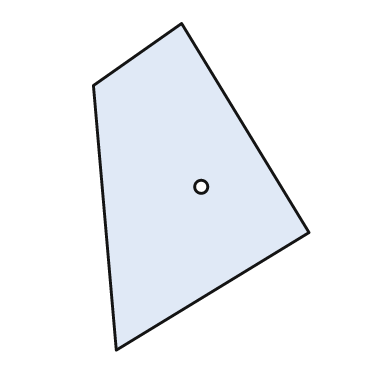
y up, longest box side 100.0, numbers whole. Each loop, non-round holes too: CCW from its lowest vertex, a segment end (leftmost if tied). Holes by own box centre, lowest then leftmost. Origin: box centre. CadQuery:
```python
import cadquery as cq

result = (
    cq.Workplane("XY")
    .moveTo(-26.0, -50.0)
    .lineTo(33.0, -14.0)
    .lineTo(-6.0, 50.0)
    .lineTo(-33.0, 31.0)
    .close()
    .moveTo(0.0, 0.0)
    .circle(2.0)
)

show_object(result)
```